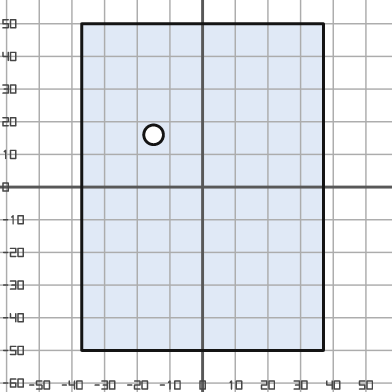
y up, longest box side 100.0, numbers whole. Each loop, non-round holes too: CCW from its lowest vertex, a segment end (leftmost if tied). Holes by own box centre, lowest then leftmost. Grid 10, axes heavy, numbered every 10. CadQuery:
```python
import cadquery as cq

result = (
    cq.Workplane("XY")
    .moveTo(-37.0, -50.0)
    .lineTo(37.0, -50.0)
    .lineTo(37.0, 50.0)
    .lineTo(-37.0, 50.0)
    .close()
    .moveTo(-15.0, 16.0)
    .circle(3.0)
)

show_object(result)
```